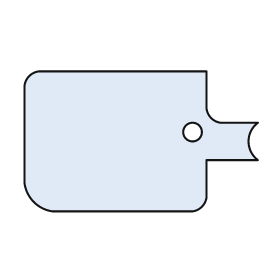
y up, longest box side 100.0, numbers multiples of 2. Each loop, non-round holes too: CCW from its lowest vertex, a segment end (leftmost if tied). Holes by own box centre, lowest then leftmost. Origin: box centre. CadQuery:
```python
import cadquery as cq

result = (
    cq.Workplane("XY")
    .moveTo(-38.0, -30.0)
    .lineTo(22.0, -30.0)
    .threePointArc((26.0, -28.0), (28.0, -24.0))
    .lineTo(28.0, -8.0)
    .lineTo(50.0, -8.0)
    .threePointArc((46.0, 0.0), (50.0, 8.0))
    .lineTo(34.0, 8.0)
    .threePointArc((30.0, 10.0), (28.0, 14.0))
    .lineTo(28.0, 30.0)
    .lineTo(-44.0, 30.0)
    .threePointArc((-48.0, 28.0), (-50.0, 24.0))
    .lineTo(-50.0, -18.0)
    .threePointArc((-46.0, -26.0), (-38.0, -30.0))
    .close()
    .moveTo(22.0, 4.0)
    .circle(4.0)
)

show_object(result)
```